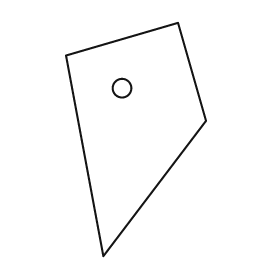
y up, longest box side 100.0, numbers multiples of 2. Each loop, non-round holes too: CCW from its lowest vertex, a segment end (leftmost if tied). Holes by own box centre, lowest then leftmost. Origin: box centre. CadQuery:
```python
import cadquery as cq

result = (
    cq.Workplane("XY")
    .moveTo(-14.0, -50.0)
    .lineTo(30.0, 8.0)
    .lineTo(18.0, 50.0)
    .lineTo(-30.0, 36.0)
    .close()
    .moveTo(-6.0, 22.0)
    .circle(4.0)
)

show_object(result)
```